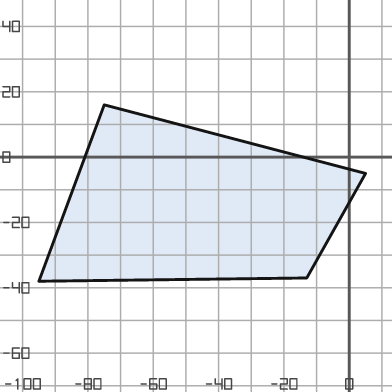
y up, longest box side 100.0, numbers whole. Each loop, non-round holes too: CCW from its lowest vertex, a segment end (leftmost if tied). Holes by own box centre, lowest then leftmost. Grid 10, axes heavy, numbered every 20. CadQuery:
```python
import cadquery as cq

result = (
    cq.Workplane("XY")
    .moveTo(-95.0, -38.0)
    .lineTo(-13.0, -37.0)
    .lineTo(5.0, -5.0)
    .lineTo(-75.0, 16.0)
    .close()
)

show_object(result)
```